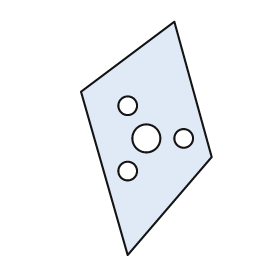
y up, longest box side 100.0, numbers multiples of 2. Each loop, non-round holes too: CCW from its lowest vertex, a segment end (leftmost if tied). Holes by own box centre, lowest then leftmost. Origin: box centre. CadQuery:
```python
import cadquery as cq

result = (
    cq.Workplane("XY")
    .moveTo(-8.0, -50.0)
    .lineTo(28.0, -8.0)
    .lineTo(12.0, 50.0)
    .lineTo(-28.0, 20.0)
    .close()
    .moveTo(-8.0, -14.0)
    .circle(4.0)
    .moveTo(0.0, 0.0)
    .circle(6.0)
    .moveTo(16.0, 0.0)
    .circle(4.0)
    .moveTo(-8.0, 14.0)
    .circle(4.0)
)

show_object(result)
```